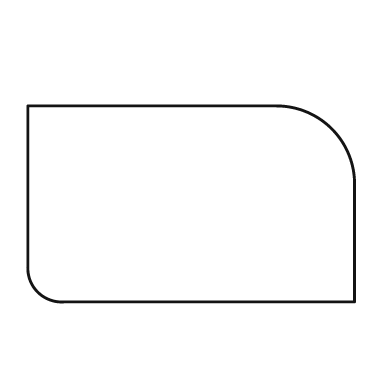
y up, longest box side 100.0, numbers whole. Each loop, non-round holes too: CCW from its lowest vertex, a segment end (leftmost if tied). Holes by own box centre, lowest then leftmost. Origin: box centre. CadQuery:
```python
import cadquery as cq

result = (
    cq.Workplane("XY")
    .moveTo(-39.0, -30.0)
    .lineTo(50.0, -30.0)
    .lineTo(50.0, 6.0)
    .threePointArc((43.0, 23.0), (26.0, 30.0))
    .lineTo(-50.0, 30.0)
    .lineTo(-50.0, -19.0)
    .threePointArc((-47.0, -27.0), (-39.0, -30.0))
    .close()
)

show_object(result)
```